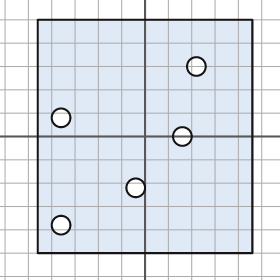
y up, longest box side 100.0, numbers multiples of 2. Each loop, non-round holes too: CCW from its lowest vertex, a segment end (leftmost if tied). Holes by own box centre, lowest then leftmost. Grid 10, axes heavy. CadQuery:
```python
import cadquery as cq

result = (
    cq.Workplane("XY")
    .moveTo(-46.0, -50.0)
    .lineTo(46.0, -50.0)
    .lineTo(46.0, 50.0)
    .lineTo(-46.0, 50.0)
    .close()
    .moveTo(-36.0, -38.0)
    .circle(4.0)
    .moveTo(-4.0, -22.0)
    .circle(4.0)
    .moveTo(16.0, 0.0)
    .circle(4.0)
    .moveTo(-36.0, 8.0)
    .circle(4.0)
    .moveTo(22.0, 30.0)
    .circle(4.0)
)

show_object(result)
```